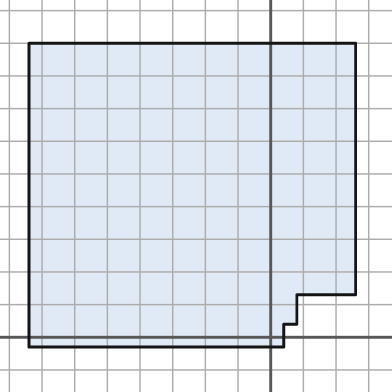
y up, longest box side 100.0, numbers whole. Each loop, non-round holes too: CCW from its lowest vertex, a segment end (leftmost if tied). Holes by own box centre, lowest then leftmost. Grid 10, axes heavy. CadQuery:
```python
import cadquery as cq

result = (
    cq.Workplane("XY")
    .moveTo(-74.0, -3.0)
    .lineTo(4.0, -3.0)
    .lineTo(4.0, 4.0)
    .lineTo(8.0, 4.0)
    .lineTo(8.0, 13.0)
    .lineTo(26.0, 13.0)
    .lineTo(26.0, 90.0)
    .lineTo(-74.0, 90.0)
    .close()
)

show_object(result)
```